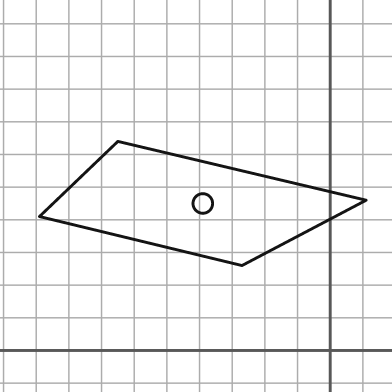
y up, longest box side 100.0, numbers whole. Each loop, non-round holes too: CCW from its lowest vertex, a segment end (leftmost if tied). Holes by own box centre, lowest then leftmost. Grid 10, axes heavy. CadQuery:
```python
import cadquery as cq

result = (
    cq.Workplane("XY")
    .moveTo(-27.0, 26.0)
    .lineTo(11.0, 46.0)
    .lineTo(-65.0, 64.0)
    .lineTo(-89.0, 41.0)
    .close()
    .moveTo(-39.0, 45.0)
    .circle(3.0)
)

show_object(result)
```